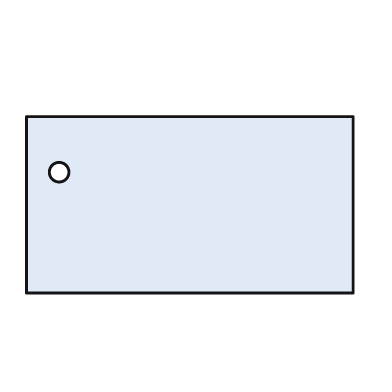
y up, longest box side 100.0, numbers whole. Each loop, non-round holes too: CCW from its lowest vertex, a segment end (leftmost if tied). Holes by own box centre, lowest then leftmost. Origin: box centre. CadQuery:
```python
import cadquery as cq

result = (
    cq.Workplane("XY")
    .moveTo(-50.0, -27.0)
    .lineTo(50.0, -27.0)
    .lineTo(50.0, 27.0)
    .lineTo(-50.0, 27.0)
    .close()
    .moveTo(-40.0, 10.0)
    .circle(3.0)
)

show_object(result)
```